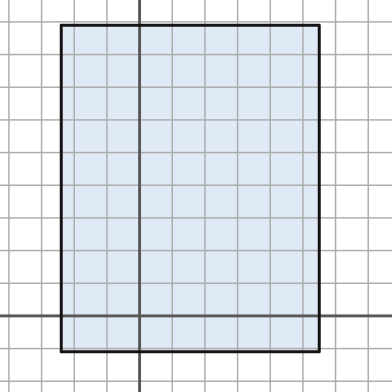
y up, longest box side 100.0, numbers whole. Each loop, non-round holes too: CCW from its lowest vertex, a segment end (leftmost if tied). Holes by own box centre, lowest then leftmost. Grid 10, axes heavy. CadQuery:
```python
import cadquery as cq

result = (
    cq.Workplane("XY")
    .moveTo(-24.0, -11.0)
    .lineTo(55.0, -11.0)
    .lineTo(55.0, 89.0)
    .lineTo(-24.0, 89.0)
    .close()
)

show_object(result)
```